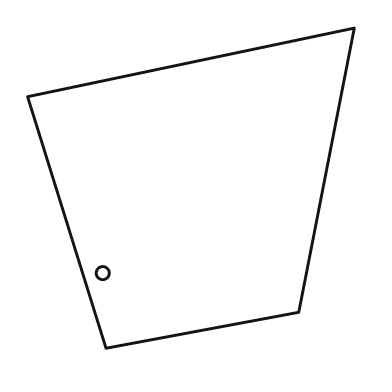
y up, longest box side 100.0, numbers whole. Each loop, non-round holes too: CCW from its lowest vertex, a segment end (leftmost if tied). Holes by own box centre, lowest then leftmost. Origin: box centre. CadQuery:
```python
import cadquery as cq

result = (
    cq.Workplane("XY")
    .moveTo(-26.0, -49.0)
    .lineTo(33.0, -38.0)
    .lineTo(50.0, 49.0)
    .lineTo(-50.0, 28.0)
    .close()
    .moveTo(-27.0, -26.0)
    .circle(2.0)
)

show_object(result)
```